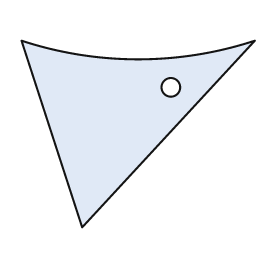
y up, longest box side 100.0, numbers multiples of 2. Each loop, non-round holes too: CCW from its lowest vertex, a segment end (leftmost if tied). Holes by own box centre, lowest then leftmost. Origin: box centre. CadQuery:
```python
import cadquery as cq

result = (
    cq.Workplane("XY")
    .moveTo(-24.0, -40.0)
    .lineTo(50.0, 40.0)
    .threePointArc((0.0, 32.0), (-50.0, 40.0))
    .close()
    .moveTo(14.0, 20.0)
    .circle(4.0)
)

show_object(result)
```